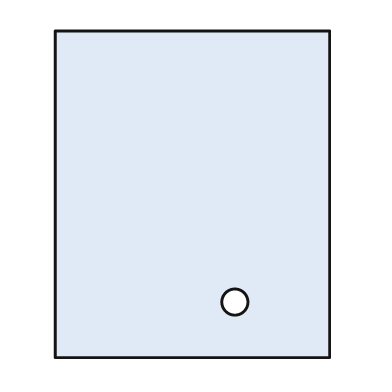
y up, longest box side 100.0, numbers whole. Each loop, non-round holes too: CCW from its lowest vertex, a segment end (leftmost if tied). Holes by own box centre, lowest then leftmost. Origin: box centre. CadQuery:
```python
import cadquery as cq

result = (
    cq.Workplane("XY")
    .moveTo(-42.0, -50.0)
    .lineTo(42.0, -50.0)
    .lineTo(42.0, 50.0)
    .lineTo(-42.0, 50.0)
    .close()
    .moveTo(13.0, -33.0)
    .circle(4.0)
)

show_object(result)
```